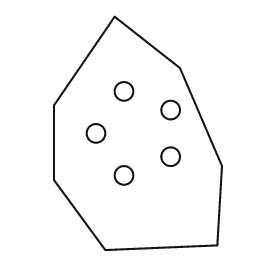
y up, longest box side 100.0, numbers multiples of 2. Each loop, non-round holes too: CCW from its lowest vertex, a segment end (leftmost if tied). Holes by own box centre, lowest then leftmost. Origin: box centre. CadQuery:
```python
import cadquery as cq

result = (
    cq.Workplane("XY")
    .moveTo(-14.0, -50.0)
    .lineTo(34.0, -48.0)
    .lineTo(36.0, -14.0)
    .lineTo(18.0, 28.0)
    .lineTo(-10.0, 50.0)
    .lineTo(-36.0, 12.0)
    .lineTo(-36.0, -20.0)
    .close()
    .moveTo(-6.0, -18.0)
    .circle(4.0)
    .moveTo(14.0, -10.0)
    .circle(4.0)
    .moveTo(-18.0, 0.0)
    .circle(4.0)
    .moveTo(14.0, 10.0)
    .circle(4.0)
    .moveTo(-6.0, 18.0)
    .circle(4.0)
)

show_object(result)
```